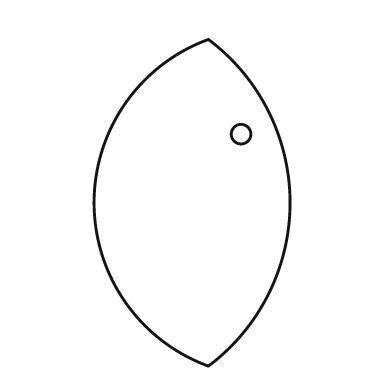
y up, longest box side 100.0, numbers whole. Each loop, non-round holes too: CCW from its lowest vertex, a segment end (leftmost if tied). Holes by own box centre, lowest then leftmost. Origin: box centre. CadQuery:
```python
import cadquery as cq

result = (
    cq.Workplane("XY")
    .moveTo(5.0, -50.0)
    .threePointArc((30.0, 0.0), (5.0, 50.0))
    .threePointArc((-30.0, 0.0), (5.0, -50.0))
    .close()
    .moveTo(15.0, 21.0)
    .circle(3.0)
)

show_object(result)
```